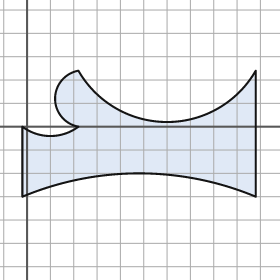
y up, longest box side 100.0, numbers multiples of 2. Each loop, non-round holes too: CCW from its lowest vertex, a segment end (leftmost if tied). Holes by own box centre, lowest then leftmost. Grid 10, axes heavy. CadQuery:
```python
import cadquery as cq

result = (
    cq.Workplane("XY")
    .moveTo(-2.0, -30.0)
    .threePointArc((48.0, -20.0), (98.0, -30.0))
    .lineTo(98.0, 24.0)
    .threePointArc((60.0, 2.0), (22.0, 24.0))
    .threePointArc((12.0, 12.0), (22.0, 0.0))
    .threePointArc((10.0, -4.0), (-2.0, 0.0))
    .close()
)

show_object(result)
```